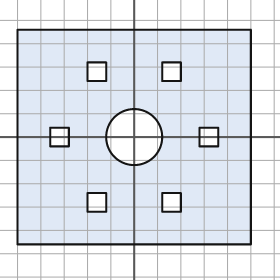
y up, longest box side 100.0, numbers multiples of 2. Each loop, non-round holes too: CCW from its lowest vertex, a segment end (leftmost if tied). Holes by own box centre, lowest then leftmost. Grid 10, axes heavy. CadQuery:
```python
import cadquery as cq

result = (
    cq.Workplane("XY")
    .moveTo(-50.0, -46.0)
    .lineTo(50.0, -46.0)
    .lineTo(50.0, 46.0)
    .lineTo(-50.0, 46.0)
    .close()
    .moveTo(-20.0, -32.0)
    .lineTo(-12.0, -32.0)
    .lineTo(-12.0, -24.0)
    .lineTo(-20.0, -24.0)
    .close()
    .moveTo(12.0, -32.0)
    .lineTo(20.0, -32.0)
    .lineTo(20.0, -24.0)
    .lineTo(12.0, -24.0)
    .close()
    .moveTo(-36.0, -4.0)
    .lineTo(-28.0, -4.0)
    .lineTo(-28.0, 4.0)
    .lineTo(-36.0, 4.0)
    .close()
    .moveTo(0.0, 0.0)
    .circle(12.0)
    .moveTo(28.0, -4.0)
    .lineTo(36.0, -4.0)
    .lineTo(36.0, 4.0)
    .lineTo(28.0, 4.0)
    .close()
    .moveTo(-20.0, 24.0)
    .lineTo(-12.0, 24.0)
    .lineTo(-12.0, 32.0)
    .lineTo(-20.0, 32.0)
    .close()
    .moveTo(12.0, 24.0)
    .lineTo(20.0, 24.0)
    .lineTo(20.0, 32.0)
    .lineTo(12.0, 32.0)
    .close()
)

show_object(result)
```